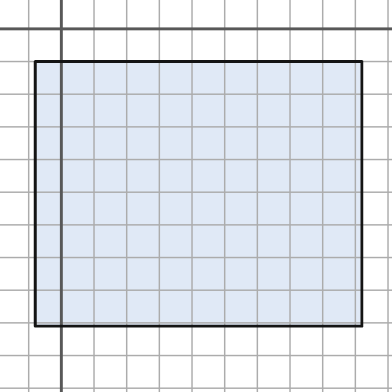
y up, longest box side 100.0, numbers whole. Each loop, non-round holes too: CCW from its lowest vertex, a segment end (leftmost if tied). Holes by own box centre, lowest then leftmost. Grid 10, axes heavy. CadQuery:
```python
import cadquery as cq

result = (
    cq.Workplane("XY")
    .moveTo(-8.0, -91.0)
    .lineTo(92.0, -91.0)
    .lineTo(92.0, -10.0)
    .lineTo(-8.0, -10.0)
    .close()
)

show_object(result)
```